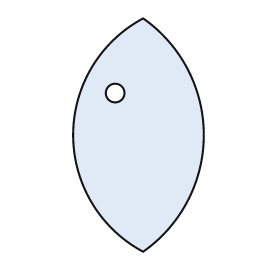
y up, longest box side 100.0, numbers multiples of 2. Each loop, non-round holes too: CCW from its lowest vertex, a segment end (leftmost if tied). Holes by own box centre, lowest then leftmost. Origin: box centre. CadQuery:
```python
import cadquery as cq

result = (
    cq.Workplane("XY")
    .moveTo(2.0, -50.0)
    .threePointArc((28.0, 0.0), (2.0, 50.0))
    .threePointArc((-28.0, 0.0), (2.0, -50.0))
    .close()
    .moveTo(-10.0, 18.0)
    .circle(4.0)
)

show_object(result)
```